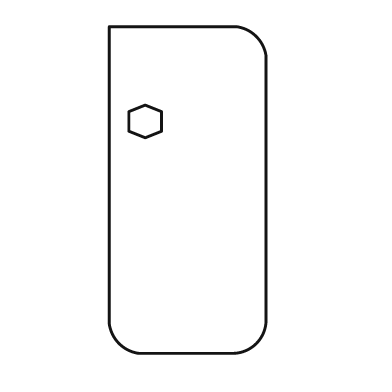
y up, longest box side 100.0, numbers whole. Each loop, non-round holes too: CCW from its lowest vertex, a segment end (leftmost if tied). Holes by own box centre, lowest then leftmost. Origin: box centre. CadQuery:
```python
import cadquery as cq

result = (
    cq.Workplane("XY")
    .moveTo(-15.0, -50.0)
    .lineTo(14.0, -50.0)
    .threePointArc((21.0, -47.0), (24.0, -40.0))
    .lineTo(24.0, 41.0)
    .threePointArc((21.0, 47.0), (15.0, 50.0))
    .lineTo(-24.0, 50.0)
    .lineTo(-24.0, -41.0)
    .threePointArc((-21.0, -47.0), (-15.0, -50.0))
    .close()
    .moveTo(-13.0, 16.0)
    .lineTo(-8.0, 18.0)
    .lineTo(-8.0, 24.0)
    .lineTo(-13.0, 26.0)
    .lineTo(-18.0, 24.0)
    .lineTo(-18.0, 18.0)
    .close()
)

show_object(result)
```